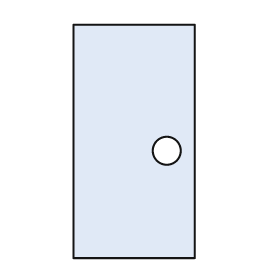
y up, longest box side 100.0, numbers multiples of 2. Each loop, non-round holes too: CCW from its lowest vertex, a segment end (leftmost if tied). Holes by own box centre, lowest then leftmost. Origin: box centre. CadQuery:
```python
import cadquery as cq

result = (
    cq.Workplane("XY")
    .moveTo(-26.0, -50.0)
    .lineTo(26.0, -50.0)
    .lineTo(26.0, 50.0)
    .lineTo(-26.0, 50.0)
    .close()
    .moveTo(14.0, -4.0)
    .circle(6.0)
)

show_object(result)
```